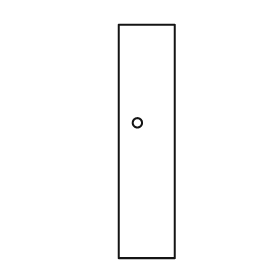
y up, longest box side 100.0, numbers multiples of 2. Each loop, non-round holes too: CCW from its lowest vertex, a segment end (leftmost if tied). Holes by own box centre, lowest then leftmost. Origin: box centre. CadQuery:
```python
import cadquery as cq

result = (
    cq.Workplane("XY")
    .moveTo(-12.0, -50.0)
    .lineTo(12.0, -50.0)
    .lineTo(12.0, 50.0)
    .lineTo(-12.0, 50.0)
    .close()
    .moveTo(-4.0, 8.0)
    .circle(2.0)
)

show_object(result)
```